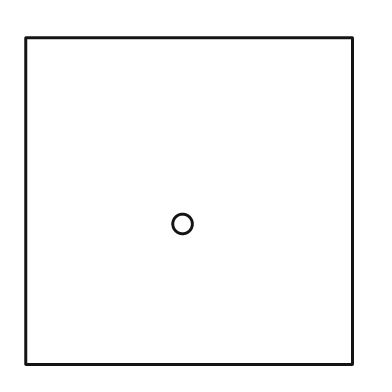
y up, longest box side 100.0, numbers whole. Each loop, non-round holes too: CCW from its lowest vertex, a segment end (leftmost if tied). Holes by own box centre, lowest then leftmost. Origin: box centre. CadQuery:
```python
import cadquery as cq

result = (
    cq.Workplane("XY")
    .moveTo(-50.0, -50.0)
    .lineTo(50.0, -50.0)
    .lineTo(50.0, 50.0)
    .lineTo(-50.0, 50.0)
    .close()
    .moveTo(-2.0, -7.0)
    .circle(3.0)
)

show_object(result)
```